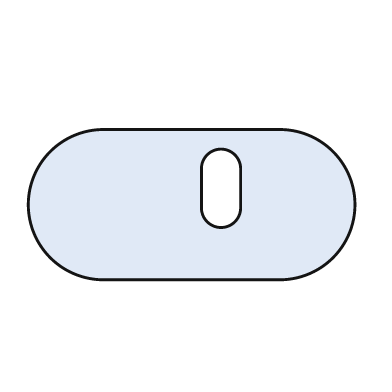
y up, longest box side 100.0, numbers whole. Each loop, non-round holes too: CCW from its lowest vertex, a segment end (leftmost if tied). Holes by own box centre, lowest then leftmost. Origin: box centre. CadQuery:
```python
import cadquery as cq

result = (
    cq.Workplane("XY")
    .moveTo(-27.0, -23.0)
    .lineTo(27.0, -23.0)
    .threePointArc((50.0, 0.0), (27.0, 23.0))
    .lineTo(-27.0, 23.0)
    .threePointArc((-50.0, 0.0), (-27.0, -23.0))
    .close()
    .moveTo(3.0, -1.0)
    .threePointArc((9.0, -7.0), (15.0, -1.0))
    .lineTo(15.0, 11.0)
    .threePointArc((9.0, 17.0), (3.0, 11.0))
    .close()
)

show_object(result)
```